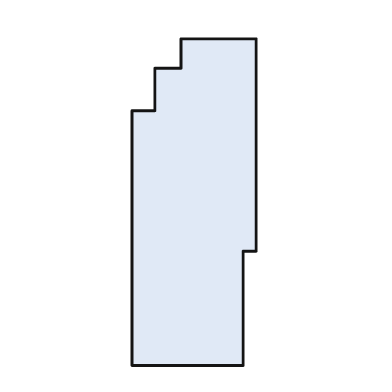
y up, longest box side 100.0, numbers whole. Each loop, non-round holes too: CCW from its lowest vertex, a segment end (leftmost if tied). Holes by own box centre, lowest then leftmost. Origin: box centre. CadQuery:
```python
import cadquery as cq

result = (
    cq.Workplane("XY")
    .moveTo(-19.0, -50.0)
    .lineTo(15.0, -50.0)
    .lineTo(15.0, -15.0)
    .lineTo(19.0, -15.0)
    .lineTo(19.0, 50.0)
    .lineTo(-4.0, 50.0)
    .lineTo(-4.0, 41.0)
    .lineTo(-12.0, 41.0)
    .lineTo(-12.0, 28.0)
    .lineTo(-19.0, 28.0)
    .close()
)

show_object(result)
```